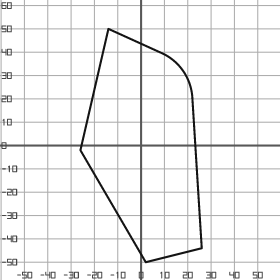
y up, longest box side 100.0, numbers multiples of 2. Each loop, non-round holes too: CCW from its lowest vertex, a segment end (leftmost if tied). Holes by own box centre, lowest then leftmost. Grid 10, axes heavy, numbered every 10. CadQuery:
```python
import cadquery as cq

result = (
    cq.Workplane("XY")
    .moveTo(2.0, -50.0)
    .lineTo(26.0, -44.0)
    .lineTo(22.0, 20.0)
    .threePointArc((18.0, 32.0), (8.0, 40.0))
    .lineTo(-14.0, 50.0)
    .lineTo(-26.0, -2.0)
    .close()
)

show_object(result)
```